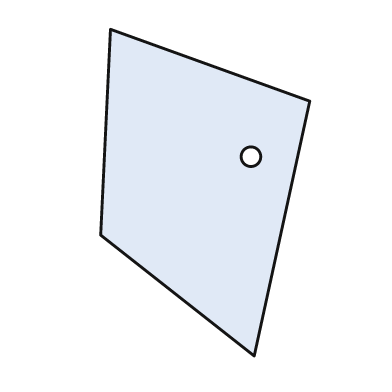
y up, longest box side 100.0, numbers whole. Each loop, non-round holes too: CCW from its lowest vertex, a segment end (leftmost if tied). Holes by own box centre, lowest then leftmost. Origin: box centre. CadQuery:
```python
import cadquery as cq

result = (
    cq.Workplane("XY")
    .moveTo(15.0, -50.0)
    .lineTo(32.0, 28.0)
    .lineTo(-29.0, 50.0)
    .lineTo(-32.0, -13.0)
    .close()
    .moveTo(14.0, 11.0)
    .circle(3.0)
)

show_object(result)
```